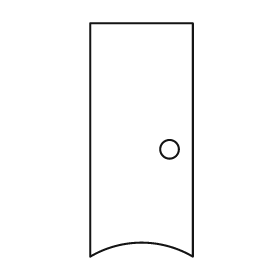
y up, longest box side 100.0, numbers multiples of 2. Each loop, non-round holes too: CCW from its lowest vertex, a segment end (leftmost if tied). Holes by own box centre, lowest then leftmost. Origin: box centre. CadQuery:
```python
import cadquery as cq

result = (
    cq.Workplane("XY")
    .moveTo(-22.0, -50.0)
    .threePointArc((0.0, -44.0), (22.0, -50.0))
    .lineTo(22.0, 50.0)
    .lineTo(-22.0, 50.0)
    .close()
    .moveTo(12.0, -4.0)
    .circle(4.0)
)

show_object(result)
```